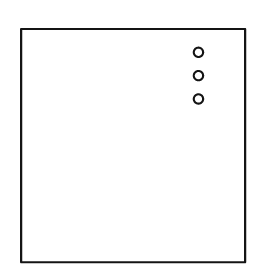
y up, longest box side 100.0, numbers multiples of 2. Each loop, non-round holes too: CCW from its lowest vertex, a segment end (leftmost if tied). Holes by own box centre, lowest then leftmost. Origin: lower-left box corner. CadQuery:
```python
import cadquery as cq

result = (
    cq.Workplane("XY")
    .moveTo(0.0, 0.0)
    .lineTo(96.0, 0.0)
    .lineTo(96.0, 100.0)
    .lineTo(0.0, 100.0)
    .close()
    .moveTo(76.0, 70.0)
    .circle(2.0)
    .moveTo(76.0, 80.0)
    .circle(2.0)
    .moveTo(76.0, 90.0)
    .circle(2.0)
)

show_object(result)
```